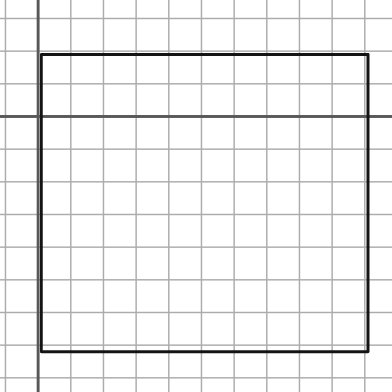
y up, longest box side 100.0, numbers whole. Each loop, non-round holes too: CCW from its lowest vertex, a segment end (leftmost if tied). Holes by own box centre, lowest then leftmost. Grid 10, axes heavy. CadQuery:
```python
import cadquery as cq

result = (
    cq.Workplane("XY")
    .moveTo(1.0, -72.0)
    .lineTo(101.0, -72.0)
    .lineTo(101.0, 19.0)
    .lineTo(1.0, 19.0)
    .close()
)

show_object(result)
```